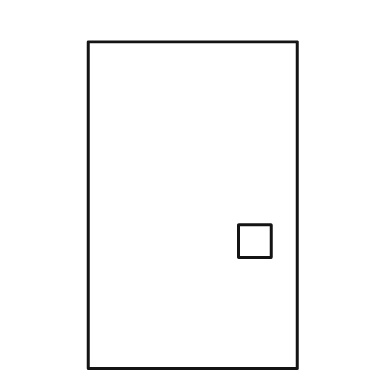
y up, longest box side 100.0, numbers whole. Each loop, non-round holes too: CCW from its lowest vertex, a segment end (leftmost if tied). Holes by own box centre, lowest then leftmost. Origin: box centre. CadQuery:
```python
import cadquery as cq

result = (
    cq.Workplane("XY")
    .moveTo(-32.0, -50.0)
    .lineTo(32.0, -50.0)
    .lineTo(32.0, 50.0)
    .lineTo(-32.0, 50.0)
    .close()
    .moveTo(14.0, -16.0)
    .lineTo(24.0, -16.0)
    .lineTo(24.0, -6.0)
    .lineTo(14.0, -6.0)
    .close()
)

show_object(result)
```